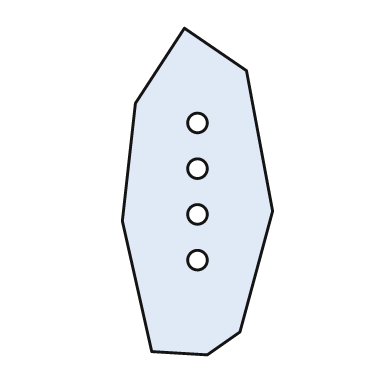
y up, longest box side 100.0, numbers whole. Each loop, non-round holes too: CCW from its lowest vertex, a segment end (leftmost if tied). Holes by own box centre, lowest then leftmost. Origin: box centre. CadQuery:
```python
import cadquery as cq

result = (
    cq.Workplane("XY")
    .moveTo(3.0, -50.0)
    .lineTo(13.0, -43.0)
    .lineTo(23.0, -6.0)
    .lineTo(15.0, 37.0)
    .lineTo(-4.0, 50.0)
    .lineTo(-19.0, 27.0)
    .lineTo(-23.0, -9.0)
    .lineTo(-14.0, -49.0)
    .close()
    .moveTo(0.0, -21.0)
    .circle(3.0)
    .moveTo(0.0, -7.0)
    .circle(3.0)
    .moveTo(0.0, 7.0)
    .circle(3.0)
    .moveTo(0.0, 21.0)
    .circle(3.0)
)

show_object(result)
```